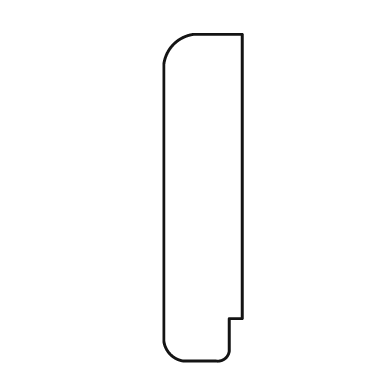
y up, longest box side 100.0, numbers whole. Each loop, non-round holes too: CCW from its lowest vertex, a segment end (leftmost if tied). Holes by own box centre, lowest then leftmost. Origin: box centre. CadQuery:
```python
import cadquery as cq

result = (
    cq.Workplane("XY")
    .moveTo(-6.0, -50.0)
    .lineTo(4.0, -50.0)
    .threePointArc((7.0, -49.0), (8.0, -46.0))
    .lineTo(8.0, -37.0)
    .lineTo(12.0, -37.0)
    .lineTo(12.0, 50.0)
    .lineTo(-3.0, 50.0)
    .threePointArc((-9.0, 47.0), (-12.0, 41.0))
    .lineTo(-12.0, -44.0)
    .threePointArc((-10.0, -48.0), (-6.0, -50.0))
    .close()
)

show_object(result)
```